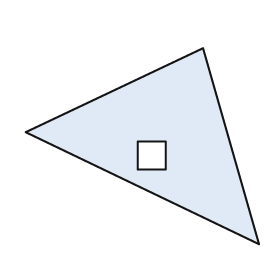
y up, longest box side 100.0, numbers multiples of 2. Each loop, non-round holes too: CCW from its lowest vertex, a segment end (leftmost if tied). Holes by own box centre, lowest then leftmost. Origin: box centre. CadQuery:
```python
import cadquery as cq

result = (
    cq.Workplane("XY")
    .moveTo(50.0, -42.0)
    .lineTo(26.0, 42.0)
    .lineTo(-50.0, 6.0)
    .close()
    .moveTo(-2.0, -10.0)
    .lineTo(10.0, -10.0)
    .lineTo(10.0, 2.0)
    .lineTo(-2.0, 2.0)
    .close()
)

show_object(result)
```